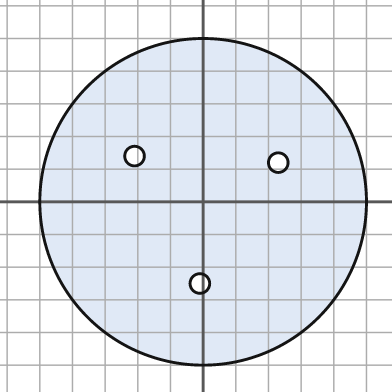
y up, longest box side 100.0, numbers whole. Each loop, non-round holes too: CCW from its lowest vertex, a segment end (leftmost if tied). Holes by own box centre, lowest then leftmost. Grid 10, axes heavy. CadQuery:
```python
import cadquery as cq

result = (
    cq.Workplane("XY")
    .moveTo(0.0, 0.0)
    .circle(50.0)
    .moveTo(-1.0, -25.0)
    .circle(3.0)
    .moveTo(23.0, 12.0)
    .circle(3.0)
    .moveTo(-21.0, 14.0)
    .circle(3.0)
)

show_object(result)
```